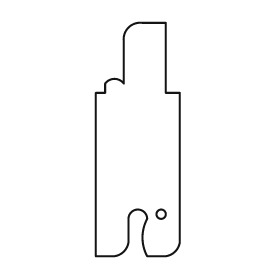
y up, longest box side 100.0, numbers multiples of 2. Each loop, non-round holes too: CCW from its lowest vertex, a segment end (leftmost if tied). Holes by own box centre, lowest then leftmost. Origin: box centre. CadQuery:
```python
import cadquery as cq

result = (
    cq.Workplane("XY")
    .moveTo(-18.0, -50.0)
    .lineTo(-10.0, -50.0)
    .threePointArc((-6.0, -48.0), (-4.0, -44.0))
    .lineTo(-4.0, -34.0)
    .threePointArc((0.0, -30.0), (4.0, -34.0))
    .threePointArc((2.0, -42.0), (4.0, -50.0))
    .lineTo(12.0, -50.0)
    .threePointArc((16.0, -48.0), (18.0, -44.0))
    .lineTo(18.0, 20.0)
    .lineTo(12.0, 20.0)
    .lineTo(12.0, 50.0)
    .lineTo(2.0, 50.0)
    .threePointArc((-4.0, 48.0), (-6.0, 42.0))
    .lineTo(-6.0, 24.0)
    .threePointArc((-10.0, 26.0), (-14.0, 24.0))
    .lineTo(-14.0, 20.0)
    .lineTo(-18.0, 20.0)
    .close()
    .moveTo(10.0, -32.0)
    .circle(2.0)
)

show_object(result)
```